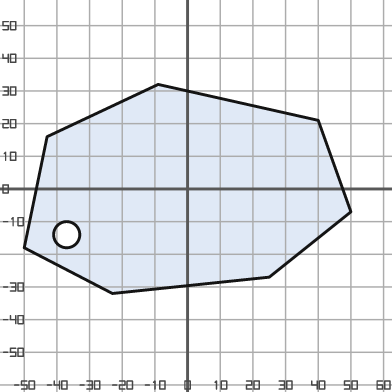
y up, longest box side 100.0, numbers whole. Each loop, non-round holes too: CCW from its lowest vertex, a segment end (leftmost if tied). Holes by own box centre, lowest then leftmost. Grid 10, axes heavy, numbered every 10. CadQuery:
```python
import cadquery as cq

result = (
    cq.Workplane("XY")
    .moveTo(-23.0, -32.0)
    .lineTo(25.0, -27.0)
    .lineTo(50.0, -7.0)
    .lineTo(40.0, 21.0)
    .lineTo(-9.0, 32.0)
    .lineTo(-43.0, 16.0)
    .lineTo(-50.0, -18.0)
    .close()
    .moveTo(-37.0, -14.0)
    .circle(4.0)
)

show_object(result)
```